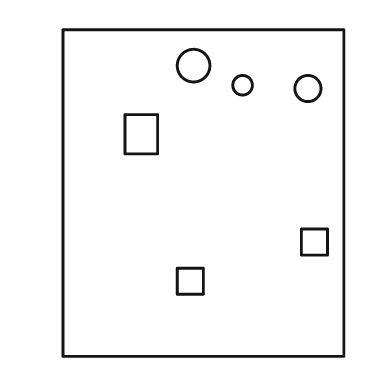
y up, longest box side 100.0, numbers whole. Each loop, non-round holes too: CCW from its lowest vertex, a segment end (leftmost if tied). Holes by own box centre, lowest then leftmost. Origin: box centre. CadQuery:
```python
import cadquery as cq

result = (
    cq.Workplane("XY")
    .moveTo(-43.0, -50.0)
    .lineTo(43.0, -50.0)
    .lineTo(43.0, 50.0)
    .lineTo(-43.0, 50.0)
    .close()
    .moveTo(-8.0, -31.0)
    .lineTo(0.0, -31.0)
    .lineTo(0.0, -23.0)
    .lineTo(-8.0, -23.0)
    .close()
    .moveTo(30.0, -19.0)
    .lineTo(38.0, -19.0)
    .lineTo(38.0, -11.0)
    .lineTo(30.0, -11.0)
    .close()
    .moveTo(-24.0, 12.0)
    .lineTo(-14.0, 12.0)
    .lineTo(-14.0, 24.0)
    .lineTo(-24.0, 24.0)
    .close()
    .moveTo(32.0, 32.0)
    .circle(4.0)
    .moveTo(12.0, 33.0)
    .circle(3.0)
    .moveTo(-3.0, 39.0)
    .circle(5.0)
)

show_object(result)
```